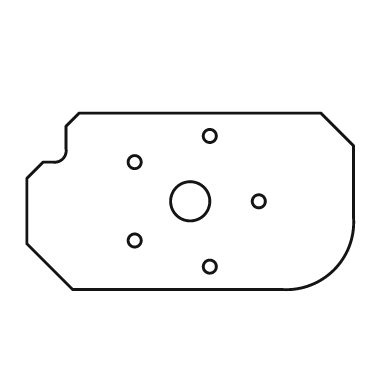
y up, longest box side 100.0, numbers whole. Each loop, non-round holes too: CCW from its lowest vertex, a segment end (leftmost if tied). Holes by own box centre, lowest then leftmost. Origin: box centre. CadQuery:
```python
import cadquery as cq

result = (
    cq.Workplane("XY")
    .moveTo(-36.0, -27.0)
    .lineTo(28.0, -27.0)
    .threePointArc((44.0, -21.0), (50.0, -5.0))
    .lineTo(50.0, 17.0)
    .lineTo(40.0, 27.0)
    .lineTo(-34.0, 27.0)
    .lineTo(-38.0, 23.0)
    .lineTo(-38.0, 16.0)
    .threePointArc((-39.0, 13.0), (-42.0, 12.0))
    .lineTo(-45.0, 12.0)
    .lineTo(-50.0, 7.0)
    .lineTo(-50.0, -13.0)
    .close()
    .moveTo(6.0, -20.0)
    .circle(2.0)
    .moveTo(-17.0, -12.0)
    .circle(2.0)
    .moveTo(0.0, 0.0)
    .circle(6.0)
    .moveTo(21.0, 0.0)
    .circle(2.0)
    .moveTo(-17.0, 12.0)
    .circle(2.0)
    .moveTo(6.0, 20.0)
    .circle(2.0)
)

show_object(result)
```